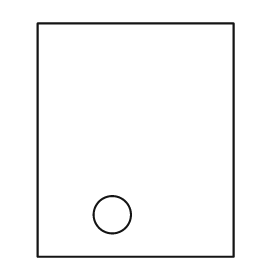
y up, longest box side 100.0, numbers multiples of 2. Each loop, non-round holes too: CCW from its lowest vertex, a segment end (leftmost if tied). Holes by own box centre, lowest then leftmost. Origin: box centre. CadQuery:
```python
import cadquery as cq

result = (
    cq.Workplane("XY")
    .moveTo(-42.0, -50.0)
    .lineTo(42.0, -50.0)
    .lineTo(42.0, 50.0)
    .lineTo(-42.0, 50.0)
    .close()
    .moveTo(-10.0, -32.0)
    .circle(8.0)
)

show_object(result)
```